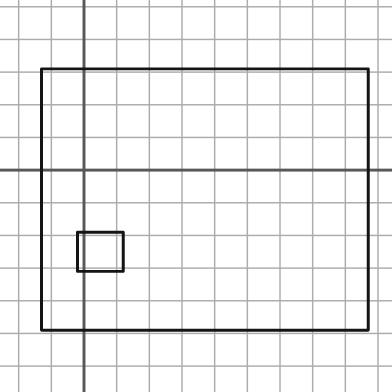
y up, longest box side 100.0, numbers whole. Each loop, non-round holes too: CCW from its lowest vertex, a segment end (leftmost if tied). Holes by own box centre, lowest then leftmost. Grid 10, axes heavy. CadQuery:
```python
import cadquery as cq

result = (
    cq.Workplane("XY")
    .moveTo(-13.0, -49.0)
    .lineTo(87.0, -49.0)
    .lineTo(87.0, 31.0)
    .lineTo(-13.0, 31.0)
    .close()
    .moveTo(-2.0, -31.0)
    .lineTo(12.0, -31.0)
    .lineTo(12.0, -19.0)
    .lineTo(-2.0, -19.0)
    .close()
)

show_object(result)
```